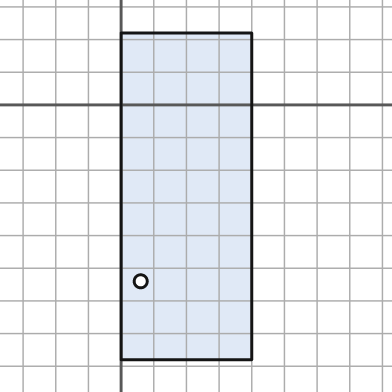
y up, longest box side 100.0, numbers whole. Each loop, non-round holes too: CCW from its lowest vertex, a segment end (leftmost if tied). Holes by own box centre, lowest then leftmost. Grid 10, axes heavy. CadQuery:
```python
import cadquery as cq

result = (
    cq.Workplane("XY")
    .moveTo(0.0, -78.0)
    .lineTo(40.0, -78.0)
    .lineTo(40.0, 22.0)
    .lineTo(0.0, 22.0)
    .close()
    .moveTo(6.0, -54.0)
    .circle(2.0)
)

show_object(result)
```